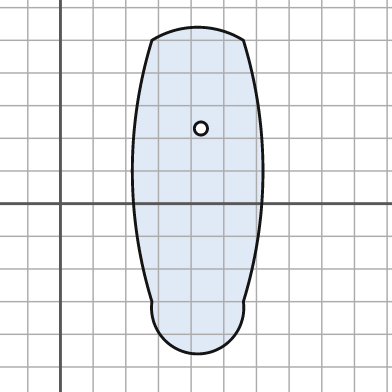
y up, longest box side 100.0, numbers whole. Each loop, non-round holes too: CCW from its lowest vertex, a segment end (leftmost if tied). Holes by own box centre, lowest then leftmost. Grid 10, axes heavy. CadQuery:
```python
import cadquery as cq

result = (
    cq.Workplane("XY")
    .moveTo(28.0, -30.0)
    .threePointArc((42.0, -46.0), (56.0, -30.0))
    .threePointArc((62.0, 10.0), (56.0, 50.0))
    .threePointArc((42.0, 54.0), (28.0, 50.0))
    .threePointArc((22.0, 10.0), (28.0, -30.0))
    .close()
    .moveTo(43.0, 23.0)
    .circle(2.0)
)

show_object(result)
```